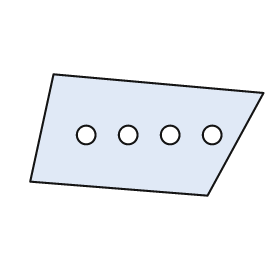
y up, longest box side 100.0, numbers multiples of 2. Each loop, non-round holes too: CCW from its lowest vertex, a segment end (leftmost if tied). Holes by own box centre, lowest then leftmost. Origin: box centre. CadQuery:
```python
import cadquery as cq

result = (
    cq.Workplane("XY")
    .moveTo(26.0, -26.0)
    .lineTo(50.0, 18.0)
    .lineTo(-40.0, 26.0)
    .lineTo(-50.0, -20.0)
    .close()
    .moveTo(-26.0, 0.0)
    .circle(4.0)
    .moveTo(-8.0, 0.0)
    .circle(4.0)
    .moveTo(10.0, 0.0)
    .circle(4.0)
    .moveTo(28.0, 0.0)
    .circle(4.0)
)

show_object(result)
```